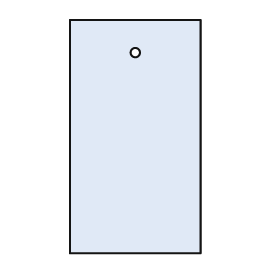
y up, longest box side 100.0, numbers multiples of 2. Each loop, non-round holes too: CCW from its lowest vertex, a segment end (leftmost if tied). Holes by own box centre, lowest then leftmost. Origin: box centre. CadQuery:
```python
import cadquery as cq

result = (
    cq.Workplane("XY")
    .moveTo(-28.0, -50.0)
    .lineTo(28.0, -50.0)
    .lineTo(28.0, 50.0)
    .lineTo(-28.0, 50.0)
    .close()
    .moveTo(0.0, 36.0)
    .circle(2.0)
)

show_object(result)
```